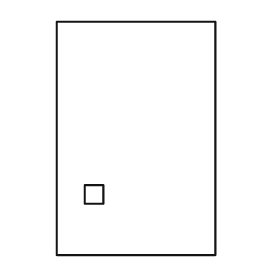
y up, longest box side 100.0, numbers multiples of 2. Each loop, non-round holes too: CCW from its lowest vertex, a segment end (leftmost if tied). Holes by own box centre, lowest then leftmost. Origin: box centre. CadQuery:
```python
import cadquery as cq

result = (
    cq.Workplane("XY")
    .moveTo(-34.0, -50.0)
    .lineTo(34.0, -50.0)
    .lineTo(34.0, 50.0)
    .lineTo(-34.0, 50.0)
    .close()
    .moveTo(-22.0, -28.0)
    .lineTo(-14.0, -28.0)
    .lineTo(-14.0, -20.0)
    .lineTo(-22.0, -20.0)
    .close()
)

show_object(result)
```